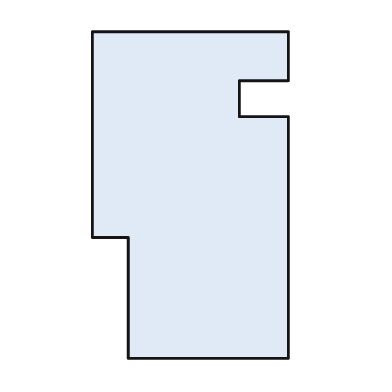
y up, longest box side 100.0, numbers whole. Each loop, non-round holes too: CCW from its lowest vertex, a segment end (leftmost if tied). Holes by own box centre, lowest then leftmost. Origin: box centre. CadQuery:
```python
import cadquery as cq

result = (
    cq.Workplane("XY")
    .moveTo(-19.0, -50.0)
    .lineTo(30.0, -50.0)
    .lineTo(30.0, 24.0)
    .lineTo(15.0, 24.0)
    .lineTo(15.0, 35.0)
    .lineTo(30.0, 35.0)
    .lineTo(30.0, 50.0)
    .lineTo(-30.0, 50.0)
    .lineTo(-30.0, -13.0)
    .lineTo(-19.0, -13.0)
    .close()
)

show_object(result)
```